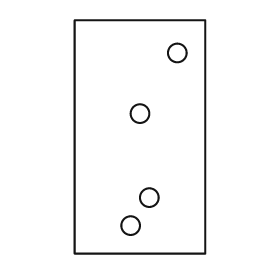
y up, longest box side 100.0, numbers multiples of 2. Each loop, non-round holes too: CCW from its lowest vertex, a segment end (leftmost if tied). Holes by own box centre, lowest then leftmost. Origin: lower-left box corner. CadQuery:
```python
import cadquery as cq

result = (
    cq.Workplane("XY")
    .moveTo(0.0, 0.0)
    .lineTo(56.0, 0.0)
    .lineTo(56.0, 100.0)
    .lineTo(0.0, 100.0)
    .close()
    .moveTo(24.0, 12.0)
    .circle(4.0)
    .moveTo(32.0, 24.0)
    .circle(4.0)
    .moveTo(28.0, 60.0)
    .circle(4.0)
    .moveTo(44.0, 86.0)
    .circle(4.0)
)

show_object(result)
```